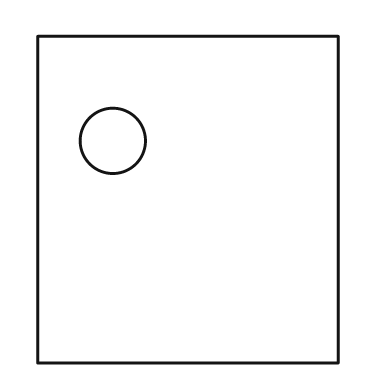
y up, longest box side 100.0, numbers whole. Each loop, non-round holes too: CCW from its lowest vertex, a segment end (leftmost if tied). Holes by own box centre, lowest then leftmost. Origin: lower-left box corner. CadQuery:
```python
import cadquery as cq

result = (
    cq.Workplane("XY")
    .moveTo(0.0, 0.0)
    .lineTo(92.0, 0.0)
    .lineTo(92.0, 100.0)
    .lineTo(0.0, 100.0)
    .close()
    .moveTo(23.0, 68.0)
    .circle(10.0)
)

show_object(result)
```